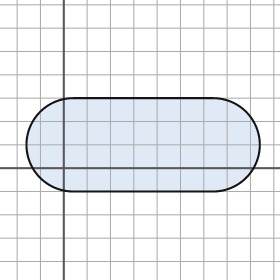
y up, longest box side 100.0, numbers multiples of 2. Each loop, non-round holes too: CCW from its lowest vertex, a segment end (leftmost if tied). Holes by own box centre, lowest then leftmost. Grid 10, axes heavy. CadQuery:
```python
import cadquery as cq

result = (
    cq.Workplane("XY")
    .moveTo(4.0, -10.0)
    .lineTo(64.0, -10.0)
    .threePointArc((84.0, 10.0), (64.0, 30.0))
    .lineTo(4.0, 30.0)
    .threePointArc((-16.0, 10.0), (4.0, -10.0))
    .close()
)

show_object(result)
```